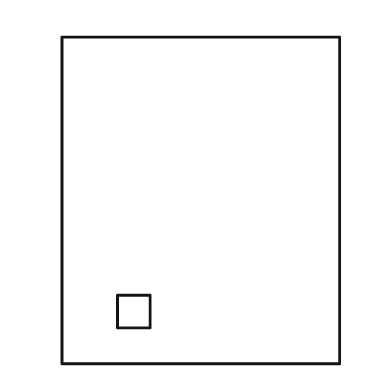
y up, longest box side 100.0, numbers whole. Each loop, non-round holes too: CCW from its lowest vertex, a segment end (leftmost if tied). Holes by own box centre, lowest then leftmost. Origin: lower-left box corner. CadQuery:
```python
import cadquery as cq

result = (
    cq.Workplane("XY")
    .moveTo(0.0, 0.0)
    .lineTo(85.0, 0.0)
    .lineTo(85.0, 100.0)
    .lineTo(0.0, 100.0)
    .close()
    .moveTo(17.0, 11.0)
    .lineTo(27.0, 11.0)
    .lineTo(27.0, 21.0)
    .lineTo(17.0, 21.0)
    .close()
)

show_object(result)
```